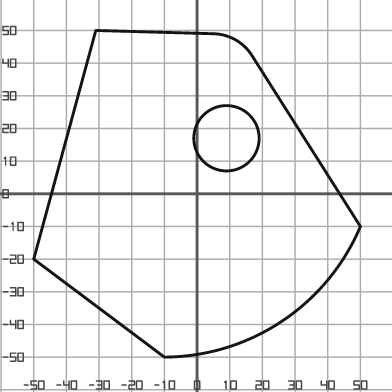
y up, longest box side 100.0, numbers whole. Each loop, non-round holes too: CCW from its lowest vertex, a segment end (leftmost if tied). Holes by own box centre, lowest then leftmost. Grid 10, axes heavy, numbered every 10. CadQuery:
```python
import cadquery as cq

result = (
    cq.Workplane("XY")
    .moveTo(-10.0, -50.0)
    .threePointArc((26.0, -39.0), (50.0, -10.0))
    .lineTo(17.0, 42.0)
    .threePointArc((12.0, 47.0), (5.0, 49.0))
    .lineTo(-31.0, 50.0)
    .lineTo(-50.0, -20.0)
    .close()
    .moveTo(9.0, 17.0)
    .circle(10.0)
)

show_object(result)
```